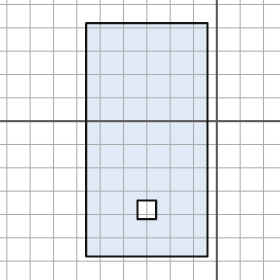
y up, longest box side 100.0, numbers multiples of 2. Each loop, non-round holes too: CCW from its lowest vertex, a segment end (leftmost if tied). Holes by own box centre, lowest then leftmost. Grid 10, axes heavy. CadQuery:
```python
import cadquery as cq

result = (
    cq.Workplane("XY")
    .moveTo(-56.0, -58.0)
    .lineTo(-4.0, -58.0)
    .lineTo(-4.0, 42.0)
    .lineTo(-56.0, 42.0)
    .close()
    .moveTo(-34.0, -42.0)
    .lineTo(-26.0, -42.0)
    .lineTo(-26.0, -34.0)
    .lineTo(-34.0, -34.0)
    .close()
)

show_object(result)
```